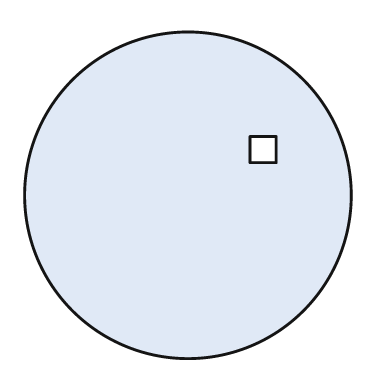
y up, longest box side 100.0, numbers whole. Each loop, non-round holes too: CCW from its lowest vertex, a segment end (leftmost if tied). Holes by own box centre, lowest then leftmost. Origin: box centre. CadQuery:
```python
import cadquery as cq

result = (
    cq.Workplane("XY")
    .moveTo(0.0, 0.0)
    .circle(50.0)
    .moveTo(19.0, 10.0)
    .lineTo(27.0, 10.0)
    .lineTo(27.0, 18.0)
    .lineTo(19.0, 18.0)
    .close()
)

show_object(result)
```